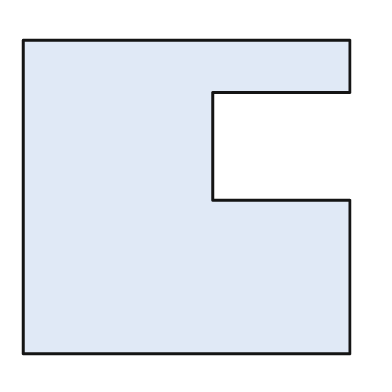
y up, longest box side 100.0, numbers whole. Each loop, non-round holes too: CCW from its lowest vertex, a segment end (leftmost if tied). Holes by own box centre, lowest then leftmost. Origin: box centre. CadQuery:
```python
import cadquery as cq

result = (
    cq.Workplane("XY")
    .moveTo(-50.0, -48.0)
    .lineTo(50.0, -48.0)
    .lineTo(50.0, -1.0)
    .lineTo(8.0, -1.0)
    .lineTo(8.0, 32.0)
    .lineTo(50.0, 32.0)
    .lineTo(50.0, 48.0)
    .lineTo(-50.0, 48.0)
    .close()
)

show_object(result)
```